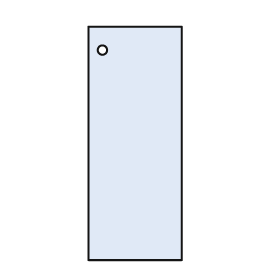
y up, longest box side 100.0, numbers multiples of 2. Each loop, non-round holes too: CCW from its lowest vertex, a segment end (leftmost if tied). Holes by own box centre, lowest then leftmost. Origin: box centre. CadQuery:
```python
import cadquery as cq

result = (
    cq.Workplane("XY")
    .moveTo(-20.0, -50.0)
    .lineTo(20.0, -50.0)
    .lineTo(20.0, 50.0)
    .lineTo(-20.0, 50.0)
    .close()
    .moveTo(-14.0, 40.0)
    .circle(2.0)
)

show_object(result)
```